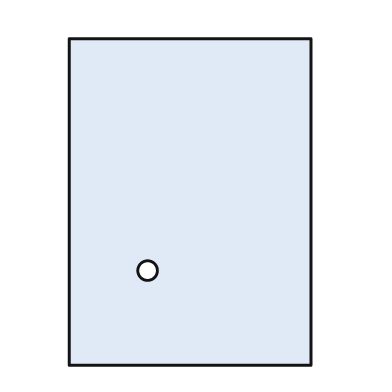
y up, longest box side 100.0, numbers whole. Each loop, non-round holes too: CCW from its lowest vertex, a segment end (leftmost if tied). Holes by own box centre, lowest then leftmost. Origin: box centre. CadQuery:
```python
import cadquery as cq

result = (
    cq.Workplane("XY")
    .moveTo(-37.0, -50.0)
    .lineTo(37.0, -50.0)
    .lineTo(37.0, 50.0)
    .lineTo(-37.0, 50.0)
    .close()
    .moveTo(-13.0, -21.0)
    .circle(3.0)
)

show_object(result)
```